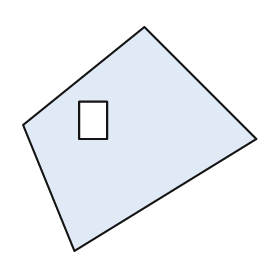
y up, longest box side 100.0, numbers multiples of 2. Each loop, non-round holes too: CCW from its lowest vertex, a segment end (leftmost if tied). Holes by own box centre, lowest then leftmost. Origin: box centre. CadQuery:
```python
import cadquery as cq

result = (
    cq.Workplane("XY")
    .moveTo(-28.0, -48.0)
    .lineTo(50.0, 0.0)
    .lineTo(2.0, 48.0)
    .lineTo(-50.0, 6.0)
    .close()
    .moveTo(-26.0, 0.0)
    .lineTo(-14.0, 0.0)
    .lineTo(-14.0, 16.0)
    .lineTo(-26.0, 16.0)
    .close()
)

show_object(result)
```